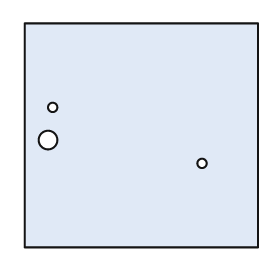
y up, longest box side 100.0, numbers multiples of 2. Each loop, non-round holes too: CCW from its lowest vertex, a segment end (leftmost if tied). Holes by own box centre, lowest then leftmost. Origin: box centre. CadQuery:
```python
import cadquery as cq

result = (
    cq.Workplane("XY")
    .moveTo(-50.0, -48.0)
    .lineTo(50.0, -48.0)
    .lineTo(50.0, 48.0)
    .lineTo(-50.0, 48.0)
    .close()
    .moveTo(26.0, -12.0)
    .circle(2.0)
    .moveTo(-40.0, -2.0)
    .circle(4.0)
    .moveTo(-38.0, 12.0)
    .circle(2.0)
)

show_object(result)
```